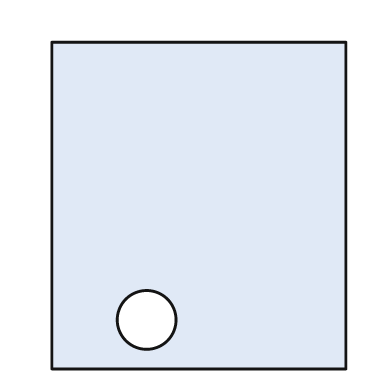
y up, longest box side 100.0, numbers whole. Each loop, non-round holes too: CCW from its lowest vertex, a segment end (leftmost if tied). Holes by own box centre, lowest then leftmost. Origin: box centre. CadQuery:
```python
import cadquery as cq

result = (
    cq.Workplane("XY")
    .moveTo(-45.0, -50.0)
    .lineTo(45.0, -50.0)
    .lineTo(45.0, 50.0)
    .lineTo(-45.0, 50.0)
    .close()
    .moveTo(-16.0, -35.0)
    .circle(9.0)
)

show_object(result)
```